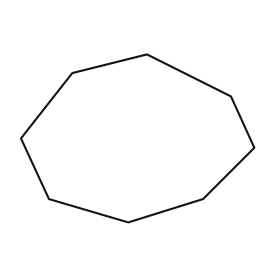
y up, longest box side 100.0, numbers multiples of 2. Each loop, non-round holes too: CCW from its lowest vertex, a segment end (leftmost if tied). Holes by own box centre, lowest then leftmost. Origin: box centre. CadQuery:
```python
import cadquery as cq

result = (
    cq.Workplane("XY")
    .moveTo(-4.0, -36.0)
    .lineTo(28.0, -26.0)
    .lineTo(50.0, -4.0)
    .lineTo(40.0, 18.0)
    .lineTo(4.0, 36.0)
    .lineTo(-28.0, 28.0)
    .lineTo(-50.0, 0.0)
    .lineTo(-38.0, -26.0)
    .close()
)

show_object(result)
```